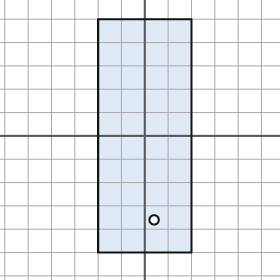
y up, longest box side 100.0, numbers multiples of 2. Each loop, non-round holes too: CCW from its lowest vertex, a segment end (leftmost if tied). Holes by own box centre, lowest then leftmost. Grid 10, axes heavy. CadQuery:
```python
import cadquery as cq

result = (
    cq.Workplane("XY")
    .moveTo(-20.0, -50.0)
    .lineTo(20.0, -50.0)
    .lineTo(20.0, 50.0)
    .lineTo(-20.0, 50.0)
    .close()
    .moveTo(4.0, -36.0)
    .circle(2.0)
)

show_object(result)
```